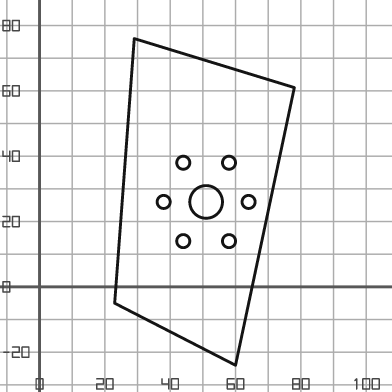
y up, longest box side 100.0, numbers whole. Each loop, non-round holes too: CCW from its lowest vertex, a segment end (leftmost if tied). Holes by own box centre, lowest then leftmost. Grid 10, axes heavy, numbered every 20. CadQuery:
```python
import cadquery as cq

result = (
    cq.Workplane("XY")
    .moveTo(60.0, -24.0)
    .lineTo(78.0, 61.0)
    .lineTo(29.0, 76.0)
    .lineTo(23.0, -5.0)
    .close()
    .moveTo(44.0, 14.0)
    .circle(2.0)
    .moveTo(58.0, 14.0)
    .circle(2.0)
    .moveTo(38.0, 26.0)
    .circle(2.0)
    .moveTo(51.0, 26.0)
    .circle(5.0)
    .moveTo(64.0, 26.0)
    .circle(2.0)
    .moveTo(44.0, 38.0)
    .circle(2.0)
    .moveTo(58.0, 38.0)
    .circle(2.0)
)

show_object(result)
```